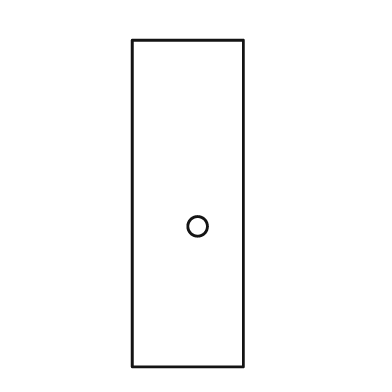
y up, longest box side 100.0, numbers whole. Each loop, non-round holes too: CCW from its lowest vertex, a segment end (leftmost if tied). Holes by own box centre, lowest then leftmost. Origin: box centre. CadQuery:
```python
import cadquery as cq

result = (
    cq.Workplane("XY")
    .moveTo(-17.0, -50.0)
    .lineTo(17.0, -50.0)
    .lineTo(17.0, 50.0)
    .lineTo(-17.0, 50.0)
    .close()
    .moveTo(3.0, -7.0)
    .circle(3.0)
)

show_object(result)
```